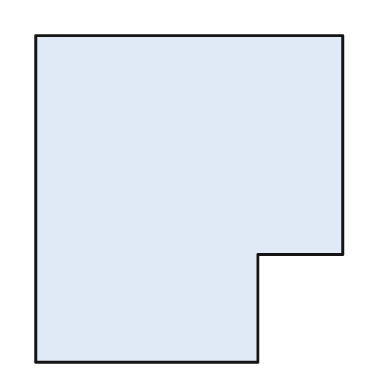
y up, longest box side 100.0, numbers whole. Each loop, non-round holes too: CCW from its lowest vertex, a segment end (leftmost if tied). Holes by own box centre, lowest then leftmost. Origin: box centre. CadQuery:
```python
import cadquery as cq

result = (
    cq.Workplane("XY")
    .moveTo(-47.0, -50.0)
    .lineTo(21.0, -50.0)
    .lineTo(21.0, -17.0)
    .lineTo(47.0, -17.0)
    .lineTo(47.0, 50.0)
    .lineTo(-47.0, 50.0)
    .close()
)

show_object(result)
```